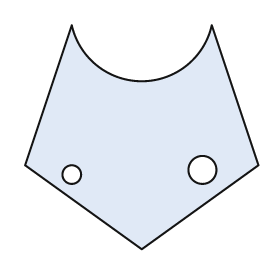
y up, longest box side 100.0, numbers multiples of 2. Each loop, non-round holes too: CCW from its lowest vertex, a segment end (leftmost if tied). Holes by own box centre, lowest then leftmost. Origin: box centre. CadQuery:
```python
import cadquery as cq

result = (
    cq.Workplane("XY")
    .moveTo(0.0, -48.0)
    .lineTo(50.0, -12.0)
    .lineTo(30.0, 48.0)
    .threePointArc((0.0, 24.0), (-30.0, 48.0))
    .lineTo(-50.0, -12.0)
    .close()
    .moveTo(-30.0, -16.0)
    .circle(4.0)
    .moveTo(26.0, -14.0)
    .circle(6.0)
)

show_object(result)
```